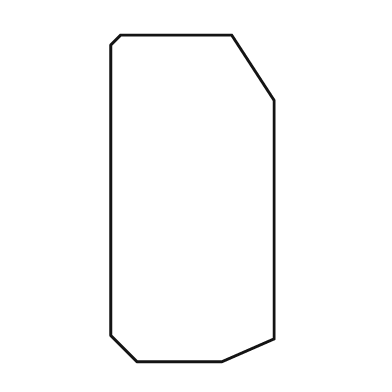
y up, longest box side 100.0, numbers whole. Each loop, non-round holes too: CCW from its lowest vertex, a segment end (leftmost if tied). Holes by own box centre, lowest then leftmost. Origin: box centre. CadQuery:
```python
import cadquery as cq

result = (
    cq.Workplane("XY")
    .moveTo(-17.0, -50.0)
    .lineTo(9.0, -50.0)
    .lineTo(25.0, -43.0)
    .lineTo(25.0, 30.0)
    .lineTo(12.0, 50.0)
    .lineTo(-22.0, 50.0)
    .lineTo(-25.0, 47.0)
    .lineTo(-25.0, -42.0)
    .close()
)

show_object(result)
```